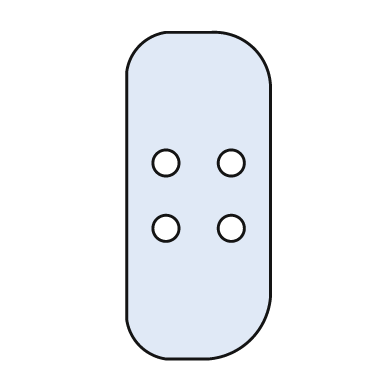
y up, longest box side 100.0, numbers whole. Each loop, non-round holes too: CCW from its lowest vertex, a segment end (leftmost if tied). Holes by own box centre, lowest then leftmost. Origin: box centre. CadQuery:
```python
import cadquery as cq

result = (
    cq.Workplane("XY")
    .moveTo(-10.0, -50.0)
    .lineTo(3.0, -50.0)
    .threePointArc((16.0, -44.0), (22.0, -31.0))
    .lineTo(22.0, 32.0)
    .threePointArc((17.0, 45.0), (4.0, 50.0))
    .lineTo(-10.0, 50.0)
    .threePointArc((-18.0, 46.0), (-22.0, 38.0))
    .lineTo(-22.0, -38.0)
    .threePointArc((-18.0, -46.0), (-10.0, -50.0))
    .close()
    .moveTo(-10.0, -10.0)
    .circle(4.0)
    .moveTo(10.0, -10.0)
    .circle(4.0)
    .moveTo(-10.0, 10.0)
    .circle(4.0)
    .moveTo(10.0, 10.0)
    .circle(4.0)
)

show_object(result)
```